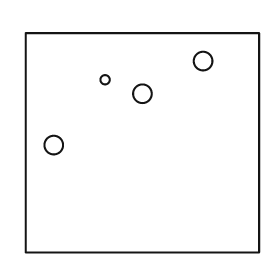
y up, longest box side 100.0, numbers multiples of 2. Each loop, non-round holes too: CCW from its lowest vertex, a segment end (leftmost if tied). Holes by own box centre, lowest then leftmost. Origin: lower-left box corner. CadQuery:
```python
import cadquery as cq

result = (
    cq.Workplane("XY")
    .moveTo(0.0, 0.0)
    .lineTo(100.0, 0.0)
    .lineTo(100.0, 94.0)
    .lineTo(0.0, 94.0)
    .close()
    .moveTo(12.0, 46.0)
    .circle(4.0)
    .moveTo(50.0, 68.0)
    .circle(4.0)
    .moveTo(34.0, 74.0)
    .circle(2.0)
    .moveTo(76.0, 82.0)
    .circle(4.0)
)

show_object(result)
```